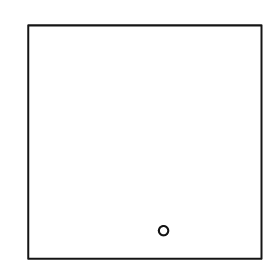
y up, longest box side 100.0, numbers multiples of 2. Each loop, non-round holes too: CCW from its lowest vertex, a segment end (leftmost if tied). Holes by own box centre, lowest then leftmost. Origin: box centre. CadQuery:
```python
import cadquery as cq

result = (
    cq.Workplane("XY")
    .moveTo(-50.0, -50.0)
    .lineTo(50.0, -50.0)
    .lineTo(50.0, 50.0)
    .lineTo(-50.0, 50.0)
    .close()
    .moveTo(8.0, -38.0)
    .circle(2.0)
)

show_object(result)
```